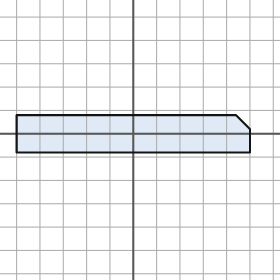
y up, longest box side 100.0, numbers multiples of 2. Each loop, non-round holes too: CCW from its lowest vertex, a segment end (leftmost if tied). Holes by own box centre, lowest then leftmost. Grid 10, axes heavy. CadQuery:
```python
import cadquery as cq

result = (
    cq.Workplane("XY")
    .moveTo(-50.0, -8.0)
    .lineTo(50.0, -8.0)
    .lineTo(50.0, 2.0)
    .lineTo(44.0, 8.0)
    .lineTo(-50.0, 8.0)
    .close()
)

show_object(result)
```